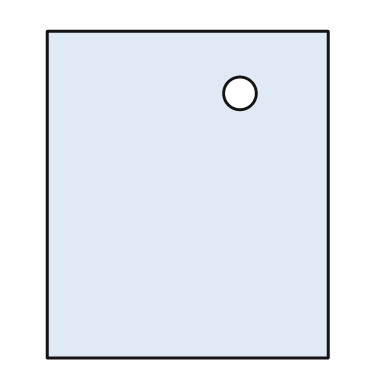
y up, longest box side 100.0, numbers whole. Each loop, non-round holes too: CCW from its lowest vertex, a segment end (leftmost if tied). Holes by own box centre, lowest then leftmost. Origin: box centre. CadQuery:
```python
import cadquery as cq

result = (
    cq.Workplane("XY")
    .moveTo(-43.0, -50.0)
    .lineTo(43.0, -50.0)
    .lineTo(43.0, 50.0)
    .lineTo(-43.0, 50.0)
    .close()
    .moveTo(16.0, 31.0)
    .circle(5.0)
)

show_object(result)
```